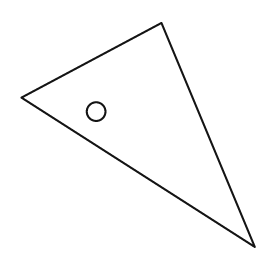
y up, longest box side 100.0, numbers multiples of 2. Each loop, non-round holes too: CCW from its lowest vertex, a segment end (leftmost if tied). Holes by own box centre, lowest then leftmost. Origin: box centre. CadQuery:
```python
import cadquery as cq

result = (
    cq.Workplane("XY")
    .moveTo(50.0, -48.0)
    .lineTo(10.0, 48.0)
    .lineTo(-50.0, 16.0)
    .close()
    .moveTo(-18.0, 10.0)
    .circle(4.0)
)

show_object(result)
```